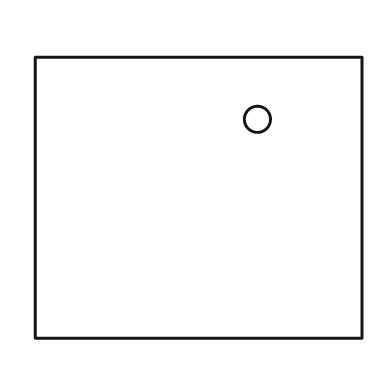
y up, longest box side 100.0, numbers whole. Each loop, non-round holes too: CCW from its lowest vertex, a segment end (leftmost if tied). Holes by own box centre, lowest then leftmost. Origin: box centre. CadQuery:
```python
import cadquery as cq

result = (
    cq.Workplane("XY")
    .moveTo(-50.0, -43.0)
    .lineTo(50.0, -43.0)
    .lineTo(50.0, 43.0)
    .lineTo(-50.0, 43.0)
    .close()
    .moveTo(18.0, 24.0)
    .circle(4.0)
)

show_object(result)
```